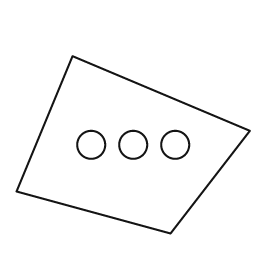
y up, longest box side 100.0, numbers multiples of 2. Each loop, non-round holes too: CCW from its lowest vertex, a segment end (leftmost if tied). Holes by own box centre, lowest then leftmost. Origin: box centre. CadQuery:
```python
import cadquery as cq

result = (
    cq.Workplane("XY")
    .moveTo(16.0, -38.0)
    .lineTo(50.0, 6.0)
    .lineTo(-26.0, 38.0)
    .lineTo(-50.0, -20.0)
    .close()
    .moveTo(-18.0, 0.0)
    .circle(6.0)
    .moveTo(0.0, 0.0)
    .circle(6.0)
    .moveTo(18.0, 0.0)
    .circle(6.0)
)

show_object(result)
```